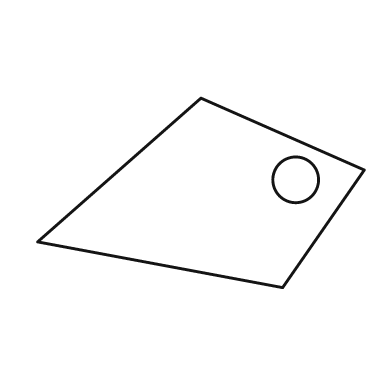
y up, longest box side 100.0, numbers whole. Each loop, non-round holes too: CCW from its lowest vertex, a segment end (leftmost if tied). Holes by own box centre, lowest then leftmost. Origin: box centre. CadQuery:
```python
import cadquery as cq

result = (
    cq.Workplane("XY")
    .moveTo(25.0, -29.0)
    .lineTo(50.0, 7.0)
    .lineTo(0.0, 29.0)
    .lineTo(-50.0, -15.0)
    .close()
    .moveTo(29.0, 4.0)
    .circle(7.0)
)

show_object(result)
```